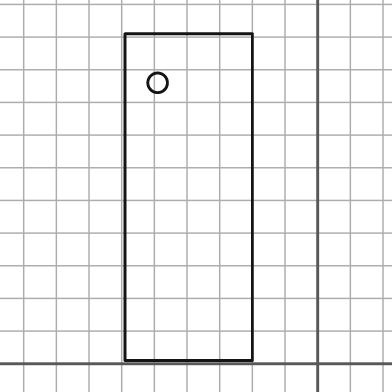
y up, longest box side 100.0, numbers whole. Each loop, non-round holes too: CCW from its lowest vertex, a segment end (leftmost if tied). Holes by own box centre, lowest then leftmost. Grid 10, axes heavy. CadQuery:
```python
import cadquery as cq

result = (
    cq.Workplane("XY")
    .moveTo(-59.0, 1.0)
    .lineTo(-20.0, 1.0)
    .lineTo(-20.0, 101.0)
    .lineTo(-59.0, 101.0)
    .close()
    .moveTo(-49.0, 86.0)
    .circle(3.0)
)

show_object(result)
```